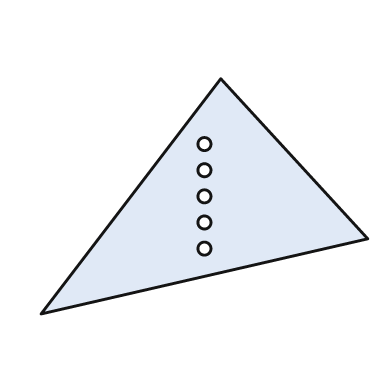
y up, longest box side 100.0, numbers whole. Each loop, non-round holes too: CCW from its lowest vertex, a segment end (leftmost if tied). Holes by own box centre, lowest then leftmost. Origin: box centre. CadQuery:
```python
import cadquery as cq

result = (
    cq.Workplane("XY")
    .moveTo(-50.0, -36.0)
    .lineTo(50.0, -13.0)
    .lineTo(5.0, 36.0)
    .close()
    .moveTo(0.0, -16.0)
    .circle(2.0)
    .moveTo(0.0, -8.0)
    .circle(2.0)
    .moveTo(0.0, 0.0)
    .circle(2.0)
    .moveTo(0.0, 8.0)
    .circle(2.0)
    .moveTo(0.0, 16.0)
    .circle(2.0)
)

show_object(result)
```